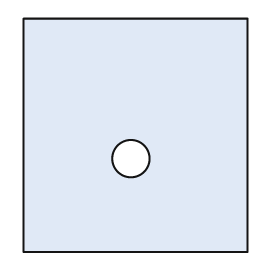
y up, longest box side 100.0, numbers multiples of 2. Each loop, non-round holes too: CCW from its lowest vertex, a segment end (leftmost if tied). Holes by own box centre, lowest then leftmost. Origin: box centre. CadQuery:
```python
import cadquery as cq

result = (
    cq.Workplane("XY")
    .moveTo(-48.0, -50.0)
    .lineTo(48.0, -50.0)
    .lineTo(48.0, 50.0)
    .lineTo(-48.0, 50.0)
    .close()
    .moveTo(-2.0, -10.0)
    .circle(8.0)
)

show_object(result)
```